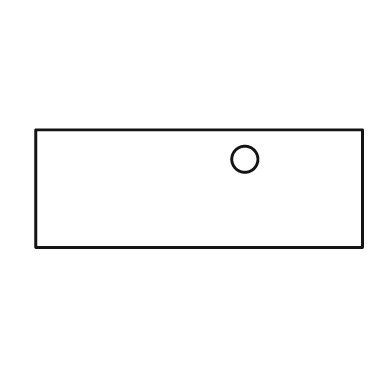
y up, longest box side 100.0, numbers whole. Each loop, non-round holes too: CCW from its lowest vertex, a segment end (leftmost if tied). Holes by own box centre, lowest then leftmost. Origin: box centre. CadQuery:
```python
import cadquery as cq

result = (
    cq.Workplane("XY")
    .moveTo(-50.0, -18.0)
    .lineTo(50.0, -18.0)
    .lineTo(50.0, 18.0)
    .lineTo(-50.0, 18.0)
    .close()
    .moveTo(14.0, 9.0)
    .circle(4.0)
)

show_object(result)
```